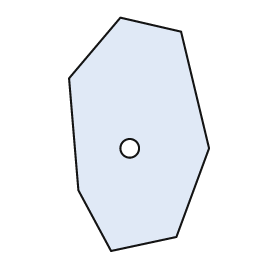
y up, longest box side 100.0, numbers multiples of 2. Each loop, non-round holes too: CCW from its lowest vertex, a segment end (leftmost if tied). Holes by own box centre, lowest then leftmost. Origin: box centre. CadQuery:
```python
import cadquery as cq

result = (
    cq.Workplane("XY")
    .moveTo(-12.0, -50.0)
    .lineTo(16.0, -44.0)
    .lineTo(30.0, -6.0)
    .lineTo(18.0, 44.0)
    .lineTo(-8.0, 50.0)
    .lineTo(-30.0, 24.0)
    .lineTo(-26.0, -24.0)
    .close()
    .moveTo(-4.0, -6.0)
    .circle(4.0)
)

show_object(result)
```